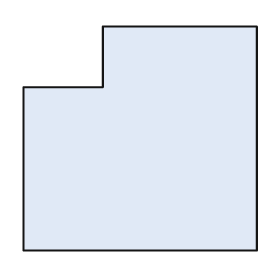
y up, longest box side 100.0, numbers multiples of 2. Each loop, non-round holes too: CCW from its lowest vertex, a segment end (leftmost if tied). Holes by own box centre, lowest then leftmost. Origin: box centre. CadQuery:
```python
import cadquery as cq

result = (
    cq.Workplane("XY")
    .moveTo(-50.0, -48.0)
    .lineTo(50.0, -48.0)
    .lineTo(50.0, 48.0)
    .lineTo(-16.0, 48.0)
    .lineTo(-16.0, 22.0)
    .lineTo(-50.0, 22.0)
    .close()
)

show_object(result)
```